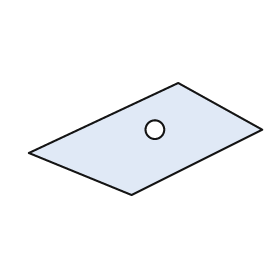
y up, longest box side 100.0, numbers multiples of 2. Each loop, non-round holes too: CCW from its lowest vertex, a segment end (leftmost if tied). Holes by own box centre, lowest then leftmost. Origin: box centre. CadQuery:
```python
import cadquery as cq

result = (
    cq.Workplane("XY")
    .moveTo(-6.0, -24.0)
    .lineTo(50.0, 4.0)
    .lineTo(14.0, 24.0)
    .lineTo(-50.0, -6.0)
    .close()
    .moveTo(4.0, 4.0)
    .circle(4.0)
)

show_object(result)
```